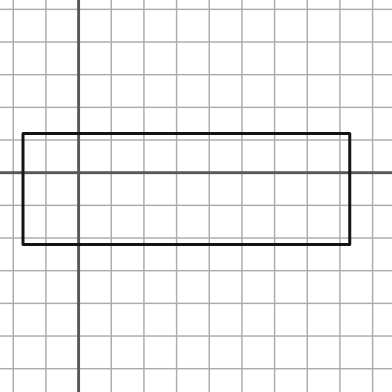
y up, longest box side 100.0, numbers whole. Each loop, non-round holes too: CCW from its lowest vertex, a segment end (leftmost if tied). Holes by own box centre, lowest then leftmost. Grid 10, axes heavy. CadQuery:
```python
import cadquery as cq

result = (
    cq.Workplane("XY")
    .moveTo(-17.0, -22.0)
    .lineTo(83.0, -22.0)
    .lineTo(83.0, 12.0)
    .lineTo(-17.0, 12.0)
    .close()
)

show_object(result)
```